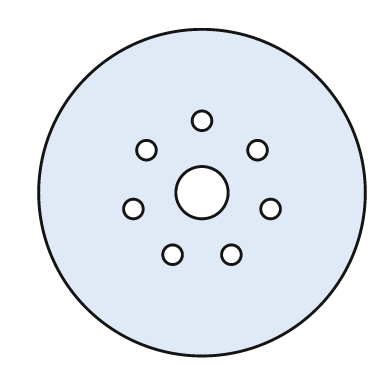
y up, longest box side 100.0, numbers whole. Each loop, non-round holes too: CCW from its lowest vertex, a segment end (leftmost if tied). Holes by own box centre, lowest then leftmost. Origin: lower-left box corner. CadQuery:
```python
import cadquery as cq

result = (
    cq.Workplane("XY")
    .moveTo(50.0, 50.0)
    .circle(50.0)
    .moveTo(41.0, 31.0)
    .circle(3.0)
    .moveTo(59.0, 31.0)
    .circle(3.0)
    .moveTo(29.0, 45.0)
    .circle(3.0)
    .moveTo(71.0, 45.0)
    .circle(3.0)
    .moveTo(50.0, 50.0)
    .circle(8.0)
    .moveTo(33.0, 63.0)
    .circle(3.0)
    .moveTo(67.0, 63.0)
    .circle(3.0)
    .moveTo(50.0, 72.0)
    .circle(3.0)
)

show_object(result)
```